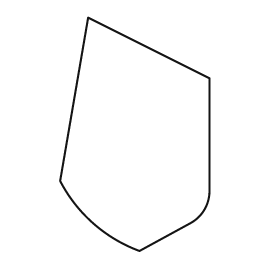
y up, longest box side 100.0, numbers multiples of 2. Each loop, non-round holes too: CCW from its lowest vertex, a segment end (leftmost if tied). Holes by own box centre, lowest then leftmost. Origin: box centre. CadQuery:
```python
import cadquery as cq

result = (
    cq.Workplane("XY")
    .moveTo(2.0, -50.0)
    .lineTo(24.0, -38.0)
    .threePointArc((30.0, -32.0), (32.0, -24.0))
    .lineTo(32.0, 24.0)
    .lineTo(-20.0, 50.0)
    .lineTo(-32.0, -20.0)
    .threePointArc((-18.0, -38.0), (2.0, -50.0))
    .close()
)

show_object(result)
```